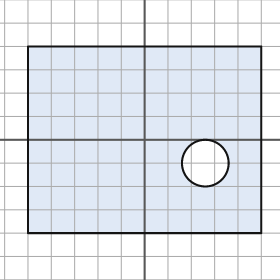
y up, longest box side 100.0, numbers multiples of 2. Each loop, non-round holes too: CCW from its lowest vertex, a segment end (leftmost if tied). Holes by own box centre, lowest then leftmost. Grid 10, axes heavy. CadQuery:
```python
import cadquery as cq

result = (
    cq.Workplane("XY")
    .moveTo(-50.0, -40.0)
    .lineTo(50.0, -40.0)
    .lineTo(50.0, 40.0)
    .lineTo(-50.0, 40.0)
    .close()
    .moveTo(26.0, -10.0)
    .circle(10.0)
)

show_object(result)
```